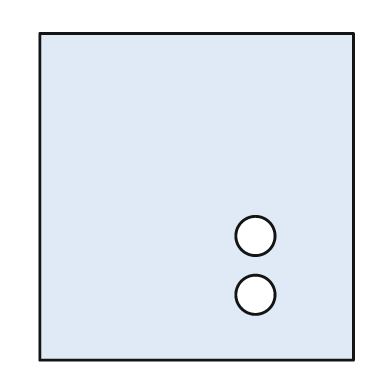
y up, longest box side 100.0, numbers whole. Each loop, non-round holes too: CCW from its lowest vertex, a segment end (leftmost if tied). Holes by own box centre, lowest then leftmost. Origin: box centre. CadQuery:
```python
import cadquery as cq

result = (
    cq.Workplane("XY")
    .moveTo(-48.0, -50.0)
    .lineTo(48.0, -50.0)
    .lineTo(48.0, 50.0)
    .lineTo(-48.0, 50.0)
    .close()
    .moveTo(18.0, -30.0)
    .circle(6.0)
    .moveTo(18.0, -12.0)
    .circle(6.0)
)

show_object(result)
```